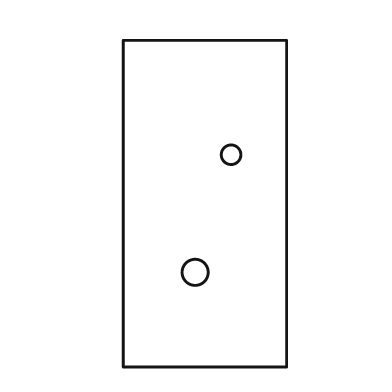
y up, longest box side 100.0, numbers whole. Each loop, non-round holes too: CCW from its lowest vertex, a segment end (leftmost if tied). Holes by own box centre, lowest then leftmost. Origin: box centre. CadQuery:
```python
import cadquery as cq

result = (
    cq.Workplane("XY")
    .moveTo(-25.0, -50.0)
    .lineTo(25.0, -50.0)
    .lineTo(25.0, 50.0)
    .lineTo(-25.0, 50.0)
    .close()
    .moveTo(-3.0, -21.0)
    .circle(4.0)
    .moveTo(8.0, 15.0)
    .circle(3.0)
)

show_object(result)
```